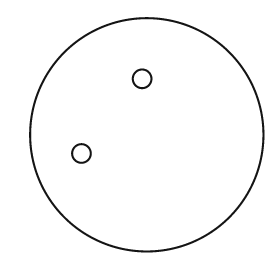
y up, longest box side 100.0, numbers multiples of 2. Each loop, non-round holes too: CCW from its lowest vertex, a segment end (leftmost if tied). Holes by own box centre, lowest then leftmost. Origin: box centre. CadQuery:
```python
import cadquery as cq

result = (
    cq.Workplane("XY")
    .moveTo(0.0, 0.0)
    .circle(50.0)
    .moveTo(-28.0, -8.0)
    .circle(4.0)
    .moveTo(-2.0, 24.0)
    .circle(4.0)
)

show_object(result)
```